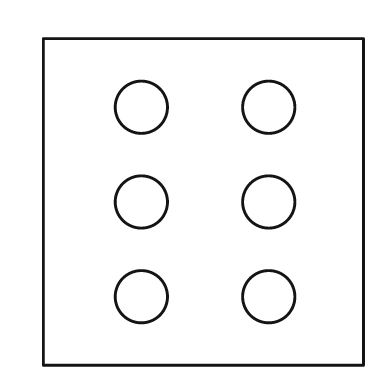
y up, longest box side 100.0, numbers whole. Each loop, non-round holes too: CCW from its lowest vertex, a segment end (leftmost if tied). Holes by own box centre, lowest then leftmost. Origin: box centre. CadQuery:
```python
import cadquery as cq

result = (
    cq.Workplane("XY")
    .moveTo(-49.0, -50.0)
    .lineTo(49.0, -50.0)
    .lineTo(49.0, 50.0)
    .lineTo(-49.0, 50.0)
    .close()
    .moveTo(-19.0, -29.0)
    .circle(8.0)
    .moveTo(20.0, -29.0)
    .circle(8.0)
    .moveTo(-19.0, 0.0)
    .circle(8.0)
    .moveTo(20.0, 0.0)
    .circle(8.0)
    .moveTo(-19.0, 29.0)
    .circle(8.0)
    .moveTo(20.0, 29.0)
    .circle(8.0)
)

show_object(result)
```